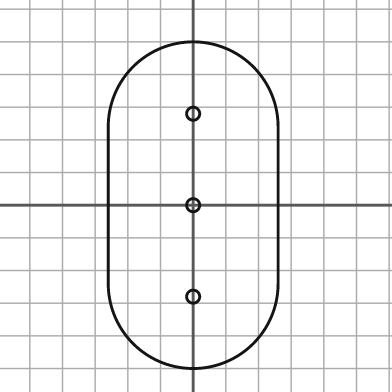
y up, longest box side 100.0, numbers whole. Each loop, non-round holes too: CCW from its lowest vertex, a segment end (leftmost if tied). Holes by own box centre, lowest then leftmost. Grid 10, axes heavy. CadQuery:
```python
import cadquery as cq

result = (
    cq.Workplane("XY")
    .moveTo(-26.0, -24.0)
    .threePointArc((0.0, -50.0), (26.0, -24.0))
    .lineTo(26.0, 24.0)
    .threePointArc((0.0, 50.0), (-26.0, 24.0))
    .close()
    .moveTo(0.0, -28.0)
    .circle(2.0)
    .moveTo(0.0, 0.0)
    .circle(2.0)
    .moveTo(0.0, 28.0)
    .circle(2.0)
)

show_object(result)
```